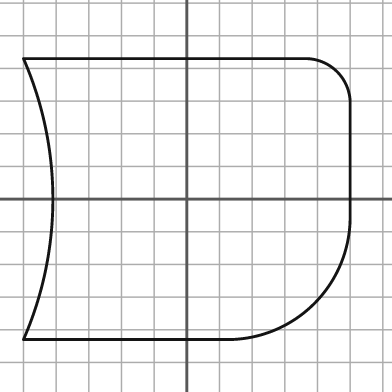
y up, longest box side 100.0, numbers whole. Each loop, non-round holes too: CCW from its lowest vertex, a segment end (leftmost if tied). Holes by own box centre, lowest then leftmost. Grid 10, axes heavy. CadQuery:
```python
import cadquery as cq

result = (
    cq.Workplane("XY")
    .moveTo(-50.0, -43.0)
    .lineTo(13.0, -43.0)
    .threePointArc((39.0, -32.0), (50.0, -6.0))
    .lineTo(50.0, 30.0)
    .threePointArc((46.0, 39.0), (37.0, 43.0))
    .lineTo(-50.0, 43.0)
    .threePointArc((-41.0, 0.0), (-50.0, -43.0))
    .close()
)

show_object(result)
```